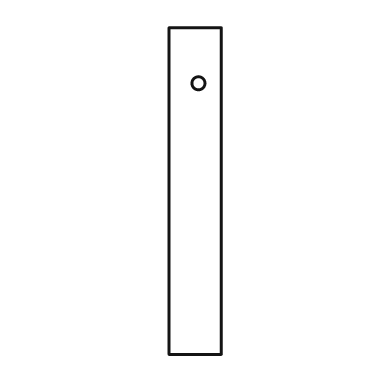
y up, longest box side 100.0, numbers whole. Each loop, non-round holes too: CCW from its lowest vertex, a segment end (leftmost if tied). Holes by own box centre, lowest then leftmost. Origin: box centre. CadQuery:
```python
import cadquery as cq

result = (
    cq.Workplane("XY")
    .moveTo(-8.0, -50.0)
    .lineTo(8.0, -50.0)
    .lineTo(8.0, 50.0)
    .lineTo(-8.0, 50.0)
    .close()
    .moveTo(1.0, 33.0)
    .circle(2.0)
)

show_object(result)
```